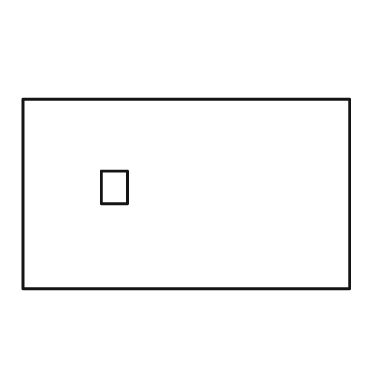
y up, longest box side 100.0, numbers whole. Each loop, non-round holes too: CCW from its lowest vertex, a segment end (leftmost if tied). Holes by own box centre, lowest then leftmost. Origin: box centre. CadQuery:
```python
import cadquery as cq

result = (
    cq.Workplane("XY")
    .moveTo(-50.0, -29.0)
    .lineTo(50.0, -29.0)
    .lineTo(50.0, 29.0)
    .lineTo(-50.0, 29.0)
    .close()
    .moveTo(-26.0, -3.0)
    .lineTo(-18.0, -3.0)
    .lineTo(-18.0, 7.0)
    .lineTo(-26.0, 7.0)
    .close()
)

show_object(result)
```